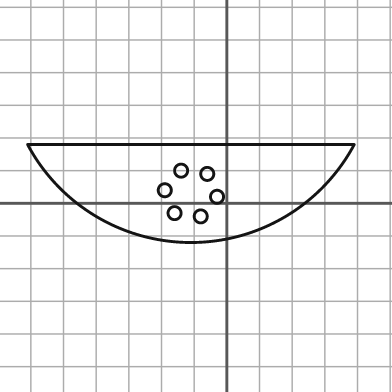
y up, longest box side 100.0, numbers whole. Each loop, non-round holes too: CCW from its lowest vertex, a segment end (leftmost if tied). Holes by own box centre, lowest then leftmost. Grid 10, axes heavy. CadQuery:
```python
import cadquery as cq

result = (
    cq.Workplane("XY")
    .moveTo(-61.0, 18.0)
    .threePointArc((-11.0, -12.0), (39.0, 18.0))
    .close()
    .moveTo(-8.0, -4.0)
    .circle(2.0)
    .moveTo(-16.0, -3.0)
    .circle(2.0)
    .moveTo(-3.0, 2.0)
    .circle(2.0)
    .moveTo(-19.0, 4.0)
    .circle(2.0)
    .moveTo(-6.0, 9.0)
    .circle(2.0)
    .moveTo(-14.0, 10.0)
    .circle(2.0)
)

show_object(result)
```